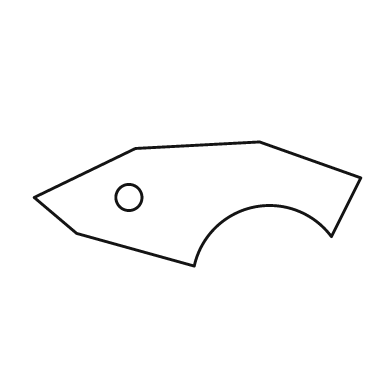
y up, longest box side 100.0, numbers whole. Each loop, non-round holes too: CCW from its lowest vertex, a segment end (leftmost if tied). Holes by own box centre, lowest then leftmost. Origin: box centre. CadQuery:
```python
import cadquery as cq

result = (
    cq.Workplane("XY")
    .moveTo(-1.0, -19.0)
    .threePointArc((17.0, -1.0), (41.0, -10.0))
    .lineTo(50.0, 8.0)
    .lineTo(19.0, 19.0)
    .lineTo(-19.0, 17.0)
    .lineTo(-50.0, 2.0)
    .lineTo(-37.0, -9.0)
    .close()
    .moveTo(-21.0, 2.0)
    .circle(4.0)
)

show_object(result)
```